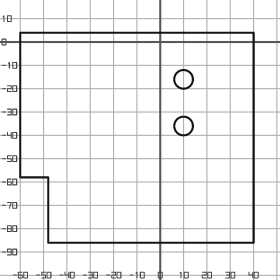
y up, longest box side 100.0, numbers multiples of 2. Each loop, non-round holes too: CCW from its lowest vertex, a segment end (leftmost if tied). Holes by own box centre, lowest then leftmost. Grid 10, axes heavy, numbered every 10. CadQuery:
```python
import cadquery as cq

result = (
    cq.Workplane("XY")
    .moveTo(-48.0, -86.0)
    .lineTo(40.0, -86.0)
    .lineTo(40.0, 4.0)
    .lineTo(-60.0, 4.0)
    .lineTo(-60.0, -58.0)
    .lineTo(-48.0, -58.0)
    .close()
    .moveTo(10.0, -36.0)
    .circle(4.0)
    .moveTo(10.0, -16.0)
    .circle(4.0)
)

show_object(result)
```